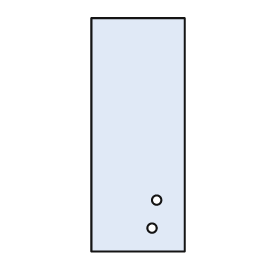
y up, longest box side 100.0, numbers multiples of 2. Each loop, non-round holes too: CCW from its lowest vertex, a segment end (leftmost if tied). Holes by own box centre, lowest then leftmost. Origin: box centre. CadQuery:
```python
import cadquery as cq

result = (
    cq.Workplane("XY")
    .moveTo(-20.0, -50.0)
    .lineTo(20.0, -50.0)
    .lineTo(20.0, 50.0)
    .lineTo(-20.0, 50.0)
    .close()
    .moveTo(6.0, -40.0)
    .circle(2.0)
    .moveTo(8.0, -28.0)
    .circle(2.0)
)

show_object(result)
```